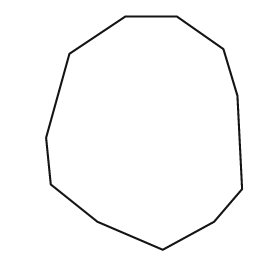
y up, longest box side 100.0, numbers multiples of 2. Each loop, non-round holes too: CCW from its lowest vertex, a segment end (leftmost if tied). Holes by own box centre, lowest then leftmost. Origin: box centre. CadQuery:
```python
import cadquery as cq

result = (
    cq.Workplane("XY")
    .moveTo(8.0, -50.0)
    .lineTo(30.0, -38.0)
    .lineTo(42.0, -24.0)
    .lineTo(40.0, 16.0)
    .lineTo(34.0, 36.0)
    .lineTo(14.0, 50.0)
    .lineTo(-8.0, 50.0)
    .lineTo(-32.0, 34.0)
    .lineTo(-42.0, -2.0)
    .lineTo(-40.0, -22.0)
    .lineTo(-20.0, -38.0)
    .close()
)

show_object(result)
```